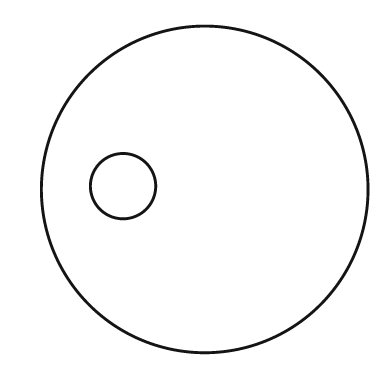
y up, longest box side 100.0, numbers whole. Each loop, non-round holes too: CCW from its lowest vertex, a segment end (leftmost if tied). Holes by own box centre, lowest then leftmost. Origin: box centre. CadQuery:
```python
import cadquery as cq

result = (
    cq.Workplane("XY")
    .moveTo(0.0, 0.0)
    .circle(50.0)
    .moveTo(-25.0, 1.0)
    .circle(10.0)
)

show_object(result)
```